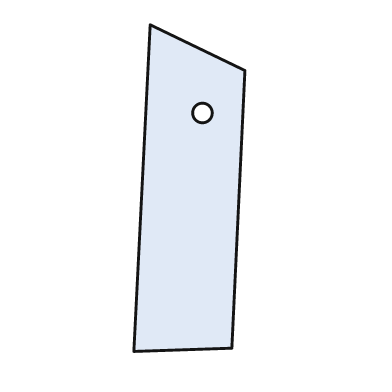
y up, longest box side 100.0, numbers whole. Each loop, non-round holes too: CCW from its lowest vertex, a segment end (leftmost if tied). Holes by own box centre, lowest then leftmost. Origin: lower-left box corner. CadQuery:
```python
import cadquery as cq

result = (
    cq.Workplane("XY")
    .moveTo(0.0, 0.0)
    .lineTo(30.0, 1.0)
    .lineTo(34.0, 86.0)
    .lineTo(5.0, 100.0)
    .close()
    .moveTo(21.0, 73.0)
    .circle(3.0)
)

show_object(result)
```